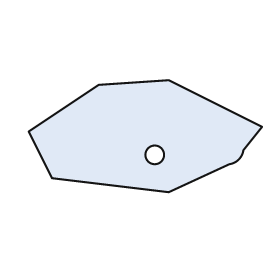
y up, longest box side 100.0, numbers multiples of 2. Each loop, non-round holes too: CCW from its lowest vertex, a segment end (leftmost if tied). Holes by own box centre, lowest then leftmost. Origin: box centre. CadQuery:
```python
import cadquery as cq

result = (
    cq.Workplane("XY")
    .moveTo(10.0, -24.0)
    .lineTo(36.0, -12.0)
    .threePointArc((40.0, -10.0), (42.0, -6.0))
    .lineTo(50.0, 4.0)
    .lineTo(10.0, 24.0)
    .lineTo(-20.0, 22.0)
    .lineTo(-50.0, 2.0)
    .lineTo(-40.0, -18.0)
    .close()
    .moveTo(4.0, -8.0)
    .circle(4.0)
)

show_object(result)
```